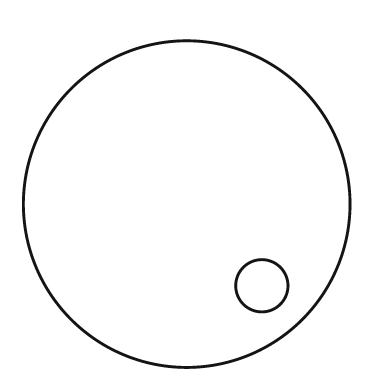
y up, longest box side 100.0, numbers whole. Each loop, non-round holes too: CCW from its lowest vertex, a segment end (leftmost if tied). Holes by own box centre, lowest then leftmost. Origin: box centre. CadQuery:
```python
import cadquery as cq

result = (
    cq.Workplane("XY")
    .moveTo(0.0, 0.0)
    .circle(50.0)
    .moveTo(23.0, -25.0)
    .circle(8.0)
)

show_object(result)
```